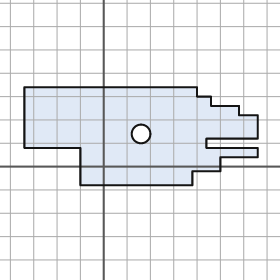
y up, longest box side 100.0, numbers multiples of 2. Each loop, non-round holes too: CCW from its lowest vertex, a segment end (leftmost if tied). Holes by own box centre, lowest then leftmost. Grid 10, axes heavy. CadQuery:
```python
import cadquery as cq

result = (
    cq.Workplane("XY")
    .moveTo(-10.0, -8.0)
    .lineTo(38.0, -8.0)
    .lineTo(38.0, -2.0)
    .lineTo(50.0, -2.0)
    .lineTo(50.0, 4.0)
    .lineTo(66.0, 4.0)
    .lineTo(66.0, 8.0)
    .lineTo(44.0, 8.0)
    .lineTo(44.0, 12.0)
    .lineTo(66.0, 12.0)
    .lineTo(66.0, 22.0)
    .lineTo(58.0, 22.0)
    .lineTo(58.0, 26.0)
    .lineTo(46.0, 26.0)
    .lineTo(46.0, 30.0)
    .lineTo(40.0, 30.0)
    .lineTo(40.0, 34.0)
    .lineTo(-34.0, 34.0)
    .lineTo(-34.0, 8.0)
    .lineTo(-10.0, 8.0)
    .close()
    .moveTo(16.0, 14.0)
    .circle(4.0)
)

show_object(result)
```